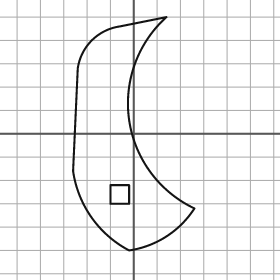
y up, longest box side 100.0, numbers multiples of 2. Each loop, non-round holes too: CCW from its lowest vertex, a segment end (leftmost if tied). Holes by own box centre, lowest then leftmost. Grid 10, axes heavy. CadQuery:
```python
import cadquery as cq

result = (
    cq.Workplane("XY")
    .moveTo(-2.0, -50.0)
    .threePointArc((14.0, -44.0), (26.0, -32.0))
    .threePointArc((-2.0, 6.0), (14.0, 50.0))
    .lineTo(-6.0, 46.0)
    .threePointArc((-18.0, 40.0), (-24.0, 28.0))
    .lineTo(-26.0, -16.0)
    .threePointArc((-18.0, -36.0), (-2.0, -50.0))
    .close()
    .moveTo(-10.0, -30.0)
    .lineTo(-2.0, -30.0)
    .lineTo(-2.0, -22.0)
    .lineTo(-10.0, -22.0)
    .close()
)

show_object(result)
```